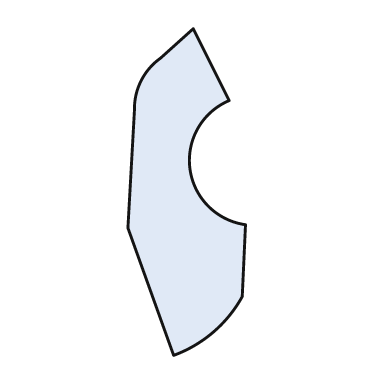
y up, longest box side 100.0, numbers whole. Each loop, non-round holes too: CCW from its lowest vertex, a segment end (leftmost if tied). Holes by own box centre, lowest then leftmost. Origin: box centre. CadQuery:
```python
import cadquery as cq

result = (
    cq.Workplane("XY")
    .moveTo(-4.0, -50.0)
    .threePointArc((8.0, -43.0), (17.0, -32.0))
    .lineTo(18.0, -10.0)
    .threePointArc((1.0, 7.0), (13.0, 28.0))
    .lineTo(2.0, 50.0)
    .lineTo(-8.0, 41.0)
    .threePointArc((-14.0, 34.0), (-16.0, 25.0))
    .lineTo(-18.0, -11.0)
    .close()
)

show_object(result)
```